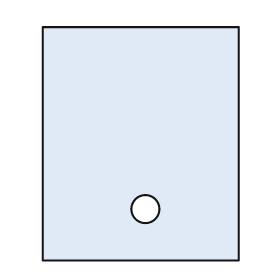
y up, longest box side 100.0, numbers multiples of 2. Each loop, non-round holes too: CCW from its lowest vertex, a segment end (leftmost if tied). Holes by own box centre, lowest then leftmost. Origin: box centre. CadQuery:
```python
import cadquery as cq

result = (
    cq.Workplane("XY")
    .moveTo(-42.0, -50.0)
    .lineTo(42.0, -50.0)
    .lineTo(42.0, 50.0)
    .lineTo(-42.0, 50.0)
    .close()
    .moveTo(2.0, -28.0)
    .circle(6.0)
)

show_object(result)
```